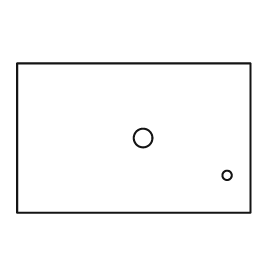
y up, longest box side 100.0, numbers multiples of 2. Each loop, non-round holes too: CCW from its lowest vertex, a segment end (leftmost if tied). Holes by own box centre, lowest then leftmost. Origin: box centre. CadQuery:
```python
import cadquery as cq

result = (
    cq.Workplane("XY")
    .moveTo(-50.0, -32.0)
    .lineTo(50.0, -32.0)
    .lineTo(50.0, 32.0)
    .lineTo(-50.0, 32.0)
    .close()
    .moveTo(40.0, -16.0)
    .circle(2.0)
    .moveTo(4.0, 0.0)
    .circle(4.0)
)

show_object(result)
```